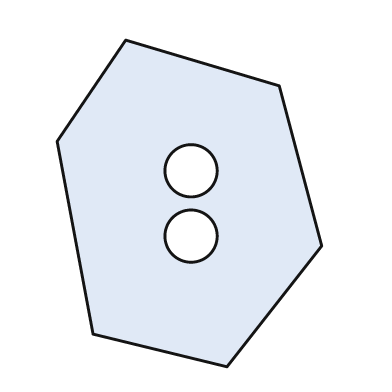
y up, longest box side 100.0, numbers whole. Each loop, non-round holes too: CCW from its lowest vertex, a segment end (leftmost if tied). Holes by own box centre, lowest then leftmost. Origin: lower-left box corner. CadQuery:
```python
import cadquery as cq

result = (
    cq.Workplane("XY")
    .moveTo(52.0, 0.0)
    .lineTo(81.0, 37.0)
    .lineTo(68.0, 86.0)
    .lineTo(21.0, 100.0)
    .lineTo(0.0, 69.0)
    .lineTo(11.0, 10.0)
    .close()
    .moveTo(41.0, 40.0)
    .circle(8.0)
    .moveTo(41.0, 60.0)
    .circle(8.0)
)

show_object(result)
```